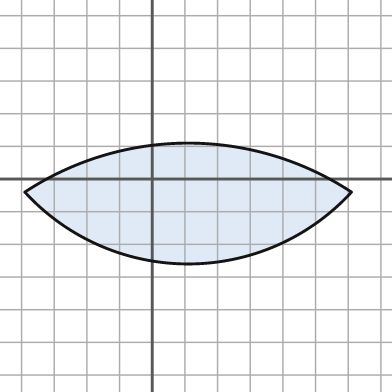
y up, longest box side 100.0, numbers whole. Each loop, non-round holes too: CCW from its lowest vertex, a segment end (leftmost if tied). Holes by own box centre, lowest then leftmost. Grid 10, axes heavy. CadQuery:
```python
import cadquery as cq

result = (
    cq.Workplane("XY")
    .moveTo(-39.0, -4.0)
    .threePointArc((11.0, -26.0), (61.0, -4.0))
    .threePointArc((11.0, 11.0), (-39.0, -4.0))
    .close()
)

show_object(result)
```